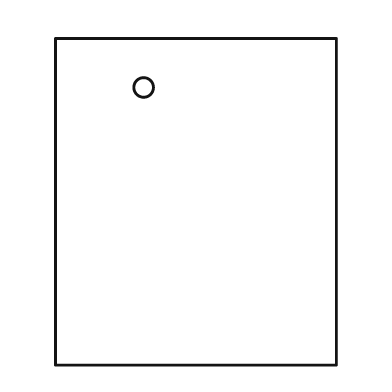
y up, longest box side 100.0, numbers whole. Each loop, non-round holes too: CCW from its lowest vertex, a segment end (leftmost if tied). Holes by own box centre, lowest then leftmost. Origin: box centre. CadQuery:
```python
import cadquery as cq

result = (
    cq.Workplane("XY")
    .moveTo(-43.0, -50.0)
    .lineTo(43.0, -50.0)
    .lineTo(43.0, 50.0)
    .lineTo(-43.0, 50.0)
    .close()
    .moveTo(-16.0, 35.0)
    .circle(3.0)
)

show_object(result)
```